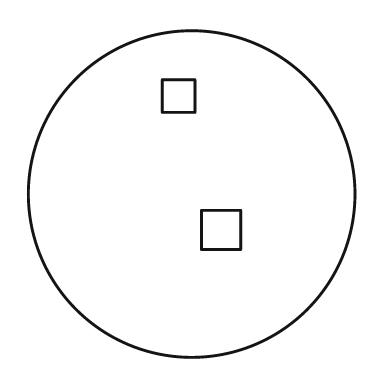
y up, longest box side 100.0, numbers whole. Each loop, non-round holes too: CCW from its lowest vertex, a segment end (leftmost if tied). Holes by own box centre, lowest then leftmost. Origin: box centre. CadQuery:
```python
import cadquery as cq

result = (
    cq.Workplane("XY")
    .moveTo(0.0, 0.0)
    .circle(50.0)
    .moveTo(3.0, -17.0)
    .lineTo(15.0, -17.0)
    .lineTo(15.0, -5.0)
    .lineTo(3.0, -5.0)
    .close()
    .moveTo(-9.0, 25.0)
    .lineTo(1.0, 25.0)
    .lineTo(1.0, 35.0)
    .lineTo(-9.0, 35.0)
    .close()
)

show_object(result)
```